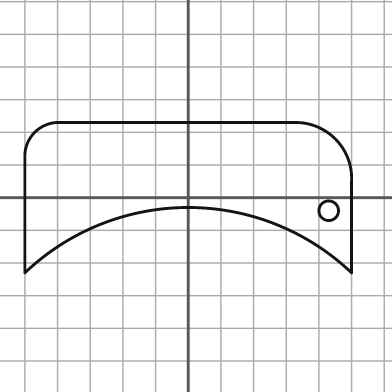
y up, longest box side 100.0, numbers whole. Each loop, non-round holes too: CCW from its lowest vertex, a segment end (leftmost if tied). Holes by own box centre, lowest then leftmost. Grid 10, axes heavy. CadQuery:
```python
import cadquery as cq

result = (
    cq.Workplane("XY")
    .moveTo(-50.0, -23.0)
    .threePointArc((0.0, -3.0), (50.0, -23.0))
    .lineTo(50.0, 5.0)
    .threePointArc((45.0, 18.0), (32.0, 23.0))
    .lineTo(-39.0, 23.0)
    .threePointArc((-47.0, 20.0), (-50.0, 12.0))
    .close()
    .moveTo(43.0, -4.0)
    .circle(3.0)
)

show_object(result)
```